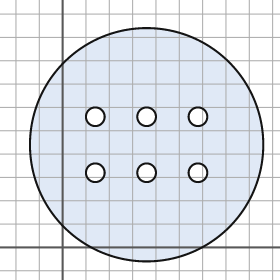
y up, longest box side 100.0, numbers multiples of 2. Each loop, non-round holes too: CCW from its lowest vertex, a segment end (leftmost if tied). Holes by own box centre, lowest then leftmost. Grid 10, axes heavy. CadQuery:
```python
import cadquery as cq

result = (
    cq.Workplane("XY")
    .moveTo(36.0, 44.0)
    .circle(50.0)
    .moveTo(14.0, 32.0)
    .circle(4.0)
    .moveTo(36.0, 32.0)
    .circle(4.0)
    .moveTo(58.0, 32.0)
    .circle(4.0)
    .moveTo(14.0, 56.0)
    .circle(4.0)
    .moveTo(36.0, 56.0)
    .circle(4.0)
    .moveTo(58.0, 56.0)
    .circle(4.0)
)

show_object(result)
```